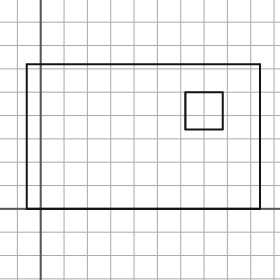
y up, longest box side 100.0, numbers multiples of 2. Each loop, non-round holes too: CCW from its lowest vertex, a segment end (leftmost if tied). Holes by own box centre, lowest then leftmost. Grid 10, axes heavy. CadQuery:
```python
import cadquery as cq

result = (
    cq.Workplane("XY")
    .moveTo(-6.0, 0.0)
    .lineTo(94.0, 0.0)
    .lineTo(94.0, 62.0)
    .lineTo(-6.0, 62.0)
    .close()
    .moveTo(62.0, 34.0)
    .lineTo(78.0, 34.0)
    .lineTo(78.0, 50.0)
    .lineTo(62.0, 50.0)
    .close()
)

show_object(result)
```